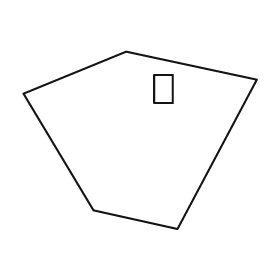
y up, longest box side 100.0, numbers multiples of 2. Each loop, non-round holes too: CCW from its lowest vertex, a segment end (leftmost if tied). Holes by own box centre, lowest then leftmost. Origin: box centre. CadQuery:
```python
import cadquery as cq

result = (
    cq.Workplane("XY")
    .moveTo(16.0, -38.0)
    .lineTo(50.0, 26.0)
    .lineTo(-6.0, 38.0)
    .lineTo(-50.0, 20.0)
    .lineTo(-20.0, -30.0)
    .close()
    .moveTo(6.0, 16.0)
    .lineTo(14.0, 16.0)
    .lineTo(14.0, 28.0)
    .lineTo(6.0, 28.0)
    .close()
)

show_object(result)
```